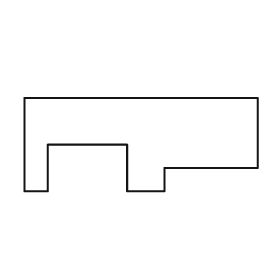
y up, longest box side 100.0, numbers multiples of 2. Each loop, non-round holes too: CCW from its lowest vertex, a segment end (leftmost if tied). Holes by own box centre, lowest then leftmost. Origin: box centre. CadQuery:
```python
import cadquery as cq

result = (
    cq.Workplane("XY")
    .moveTo(-50.0, -20.0)
    .lineTo(-40.0, -20.0)
    .lineTo(-40.0, 0.0)
    .lineTo(-6.0, 0.0)
    .lineTo(-6.0, -20.0)
    .lineTo(10.0, -20.0)
    .lineTo(10.0, -10.0)
    .lineTo(50.0, -10.0)
    .lineTo(50.0, 20.0)
    .lineTo(-50.0, 20.0)
    .close()
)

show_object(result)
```